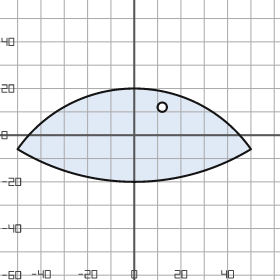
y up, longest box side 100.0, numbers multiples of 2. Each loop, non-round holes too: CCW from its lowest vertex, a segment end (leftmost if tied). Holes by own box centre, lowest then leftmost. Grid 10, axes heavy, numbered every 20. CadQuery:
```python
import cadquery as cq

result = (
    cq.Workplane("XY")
    .moveTo(-50.0, -6.0)
    .threePointArc((0.0, -20.0), (50.0, -6.0))
    .threePointArc((0.0, 20.0), (-50.0, -6.0))
    .close()
    .moveTo(12.0, 12.0)
    .circle(2.0)
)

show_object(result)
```